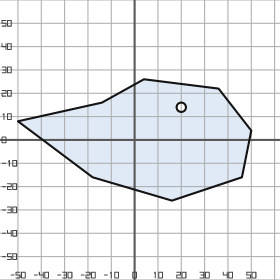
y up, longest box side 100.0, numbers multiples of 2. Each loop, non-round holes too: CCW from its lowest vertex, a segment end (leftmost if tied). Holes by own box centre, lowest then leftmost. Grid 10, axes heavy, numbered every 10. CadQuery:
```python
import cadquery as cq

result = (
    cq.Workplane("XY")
    .moveTo(16.0, -26.0)
    .lineTo(46.0, -16.0)
    .lineTo(50.0, 4.0)
    .lineTo(36.0, 22.0)
    .lineTo(4.0, 26.0)
    .lineTo(-14.0, 16.0)
    .lineTo(-50.0, 8.0)
    .lineTo(-18.0, -16.0)
    .close()
    .moveTo(20.0, 14.0)
    .circle(2.0)
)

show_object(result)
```